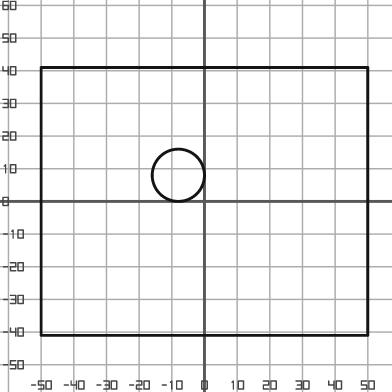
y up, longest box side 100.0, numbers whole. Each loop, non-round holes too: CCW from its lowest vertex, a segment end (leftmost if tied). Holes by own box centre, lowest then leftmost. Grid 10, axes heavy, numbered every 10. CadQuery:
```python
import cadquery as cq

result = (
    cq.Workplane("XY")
    .moveTo(-50.0, -41.0)
    .lineTo(50.0, -41.0)
    .lineTo(50.0, 41.0)
    .lineTo(-50.0, 41.0)
    .close()
    .moveTo(-8.0, 8.0)
    .circle(8.0)
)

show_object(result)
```